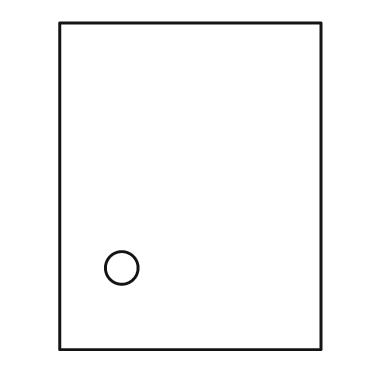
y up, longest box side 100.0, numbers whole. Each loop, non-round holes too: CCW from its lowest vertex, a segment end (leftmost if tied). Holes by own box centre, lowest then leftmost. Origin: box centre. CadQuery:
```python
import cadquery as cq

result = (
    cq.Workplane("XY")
    .moveTo(-40.0, -50.0)
    .lineTo(40.0, -50.0)
    .lineTo(40.0, 50.0)
    .lineTo(-40.0, 50.0)
    .close()
    .moveTo(-21.0, -25.0)
    .circle(5.0)
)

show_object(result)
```